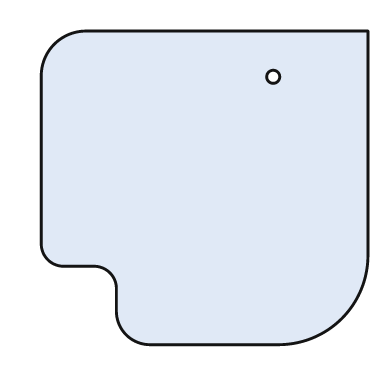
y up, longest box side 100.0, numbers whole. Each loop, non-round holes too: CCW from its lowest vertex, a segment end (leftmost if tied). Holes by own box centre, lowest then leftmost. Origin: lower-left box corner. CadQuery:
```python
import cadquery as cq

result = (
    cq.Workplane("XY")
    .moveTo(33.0, 0.0)
    .lineTo(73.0, 0.0)
    .threePointArc((92.0, 8.0), (100.0, 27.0))
    .lineTo(100.0, 96.0)
    .lineTo(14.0, 96.0)
    .threePointArc((4.0, 92.0), (0.0, 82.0))
    .lineTo(0.0, 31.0)
    .threePointArc((2.0, 26.0), (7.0, 24.0))
    .lineTo(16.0, 24.0)
    .threePointArc((21.0, 22.0), (23.0, 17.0))
    .lineTo(23.0, 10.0)
    .threePointArc((26.0, 3.0), (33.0, 0.0))
    .close()
    .moveTo(71.0, 82.0)
    .circle(2.0)
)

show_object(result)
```